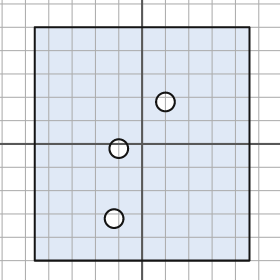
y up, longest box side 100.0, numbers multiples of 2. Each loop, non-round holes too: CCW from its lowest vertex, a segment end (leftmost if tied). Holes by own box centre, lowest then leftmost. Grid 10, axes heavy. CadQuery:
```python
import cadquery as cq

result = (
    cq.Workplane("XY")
    .moveTo(-46.0, -50.0)
    .lineTo(46.0, -50.0)
    .lineTo(46.0, 50.0)
    .lineTo(-46.0, 50.0)
    .close()
    .moveTo(-12.0, -32.0)
    .circle(4.0)
    .moveTo(-10.0, -2.0)
    .circle(4.0)
    .moveTo(10.0, 18.0)
    .circle(4.0)
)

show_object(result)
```